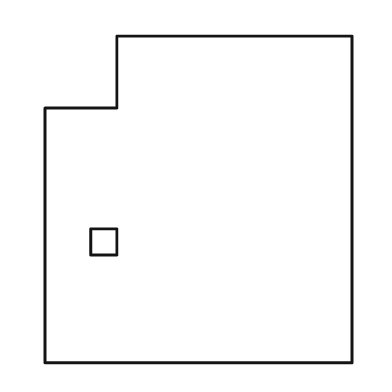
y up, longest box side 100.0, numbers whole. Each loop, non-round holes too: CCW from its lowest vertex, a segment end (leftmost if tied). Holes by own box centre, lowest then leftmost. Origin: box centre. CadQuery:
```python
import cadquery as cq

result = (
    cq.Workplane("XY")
    .moveTo(-47.0, -50.0)
    .lineTo(47.0, -50.0)
    .lineTo(47.0, 50.0)
    .lineTo(-25.0, 50.0)
    .lineTo(-25.0, 28.0)
    .lineTo(-47.0, 28.0)
    .close()
    .moveTo(-33.0, -17.0)
    .lineTo(-25.0, -17.0)
    .lineTo(-25.0, -9.0)
    .lineTo(-33.0, -9.0)
    .close()
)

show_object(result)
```